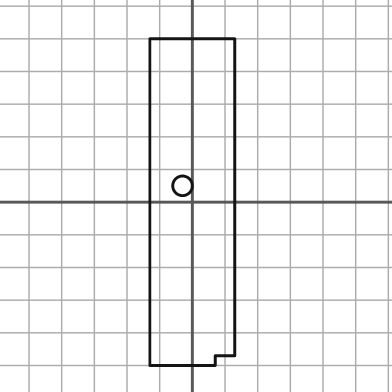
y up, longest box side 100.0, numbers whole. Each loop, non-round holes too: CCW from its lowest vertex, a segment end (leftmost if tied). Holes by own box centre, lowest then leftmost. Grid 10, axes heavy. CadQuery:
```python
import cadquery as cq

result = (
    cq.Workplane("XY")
    .moveTo(-13.0, -50.0)
    .lineTo(7.0, -50.0)
    .lineTo(7.0, -47.0)
    .lineTo(13.0, -47.0)
    .lineTo(13.0, 50.0)
    .lineTo(-13.0, 50.0)
    .close()
    .moveTo(-3.0, 5.0)
    .circle(3.0)
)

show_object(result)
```